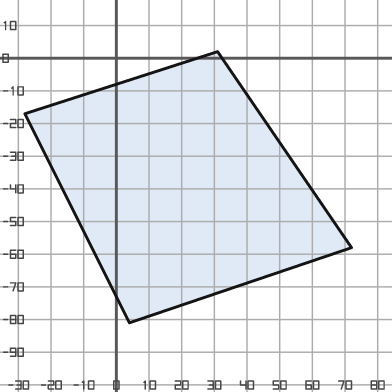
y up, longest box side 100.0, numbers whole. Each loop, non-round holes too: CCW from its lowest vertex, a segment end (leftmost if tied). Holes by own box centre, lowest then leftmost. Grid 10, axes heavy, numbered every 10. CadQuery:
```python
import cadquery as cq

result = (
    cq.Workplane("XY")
    .moveTo(4.0, -81.0)
    .lineTo(72.0, -58.0)
    .lineTo(31.0, 2.0)
    .lineTo(-28.0, -17.0)
    .close()
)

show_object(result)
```